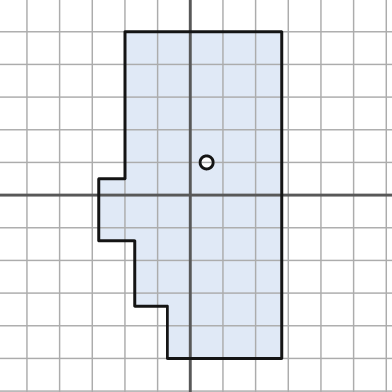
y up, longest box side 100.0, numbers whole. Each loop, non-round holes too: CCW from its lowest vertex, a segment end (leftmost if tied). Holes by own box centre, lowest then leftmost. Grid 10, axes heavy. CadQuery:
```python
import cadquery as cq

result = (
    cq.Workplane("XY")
    .moveTo(-7.0, -50.0)
    .lineTo(28.0, -50.0)
    .lineTo(28.0, 50.0)
    .lineTo(-20.0, 50.0)
    .lineTo(-20.0, 5.0)
    .lineTo(-28.0, 5.0)
    .lineTo(-28.0, -14.0)
    .lineTo(-17.0, -14.0)
    .lineTo(-17.0, -34.0)
    .lineTo(-7.0, -34.0)
    .close()
    .moveTo(5.0, 10.0)
    .circle(2.0)
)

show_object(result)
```